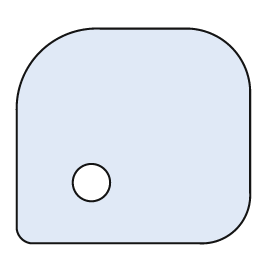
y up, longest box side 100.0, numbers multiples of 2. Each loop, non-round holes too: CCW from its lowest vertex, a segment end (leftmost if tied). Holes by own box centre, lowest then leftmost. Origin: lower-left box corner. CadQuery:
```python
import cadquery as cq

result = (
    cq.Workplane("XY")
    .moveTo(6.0, 0.0)
    .lineTo(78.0, 0.0)
    .threePointArc((94.0, 6.0), (100.0, 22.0))
    .lineTo(100.0, 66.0)
    .threePointArc((92.0, 84.0), (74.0, 92.0))
    .lineTo(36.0, 92.0)
    .threePointArc((10.0, 82.0), (0.0, 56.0))
    .lineTo(0.0, 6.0)
    .threePointArc((2.0, 2.0), (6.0, 0.0))
    .close()
    .moveTo(32.0, 26.0)
    .circle(8.0)
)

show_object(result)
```